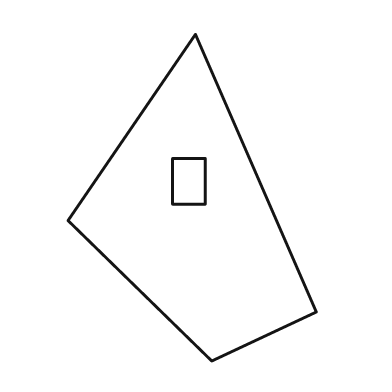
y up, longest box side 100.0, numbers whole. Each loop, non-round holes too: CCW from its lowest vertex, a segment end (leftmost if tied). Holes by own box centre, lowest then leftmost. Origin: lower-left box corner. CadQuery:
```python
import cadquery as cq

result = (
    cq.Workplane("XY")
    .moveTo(44.0, 0.0)
    .lineTo(76.0, 15.0)
    .lineTo(39.0, 100.0)
    .lineTo(0.0, 43.0)
    .close()
    .moveTo(32.0, 48.0)
    .lineTo(42.0, 48.0)
    .lineTo(42.0, 62.0)
    .lineTo(32.0, 62.0)
    .close()
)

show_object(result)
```